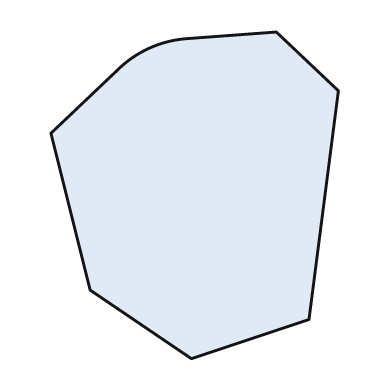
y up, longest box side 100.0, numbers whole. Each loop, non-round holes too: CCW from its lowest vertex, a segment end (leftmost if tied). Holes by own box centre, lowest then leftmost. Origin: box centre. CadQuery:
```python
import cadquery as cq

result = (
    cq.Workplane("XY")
    .moveTo(-1.0, -50.0)
    .lineTo(35.0, -38.0)
    .lineTo(44.0, 32.0)
    .lineTo(25.0, 50.0)
    .lineTo(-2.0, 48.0)
    .threePointArc((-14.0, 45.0), (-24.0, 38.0))
    .lineTo(-44.0, 19.0)
    .lineTo(-32.0, -29.0)
    .close()
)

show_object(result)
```